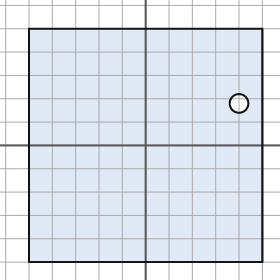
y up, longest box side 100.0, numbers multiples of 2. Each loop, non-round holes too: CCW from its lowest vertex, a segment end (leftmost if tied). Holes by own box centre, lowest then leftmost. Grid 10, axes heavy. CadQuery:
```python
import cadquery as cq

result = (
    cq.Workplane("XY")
    .moveTo(-50.0, -50.0)
    .lineTo(50.0, -50.0)
    .lineTo(50.0, 50.0)
    .lineTo(-50.0, 50.0)
    .close()
    .moveTo(40.0, 18.0)
    .circle(4.0)
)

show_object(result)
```